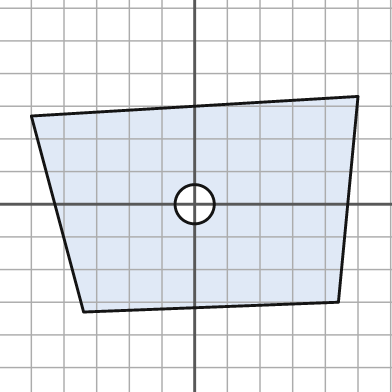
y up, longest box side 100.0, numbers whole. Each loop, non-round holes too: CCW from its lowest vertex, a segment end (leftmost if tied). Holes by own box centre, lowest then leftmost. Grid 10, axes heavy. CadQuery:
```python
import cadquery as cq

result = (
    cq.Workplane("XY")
    .moveTo(-34.0, -33.0)
    .lineTo(44.0, -30.0)
    .lineTo(50.0, 33.0)
    .lineTo(-50.0, 27.0)
    .close()
    .moveTo(0.0, 0.0)
    .circle(6.0)
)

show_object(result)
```